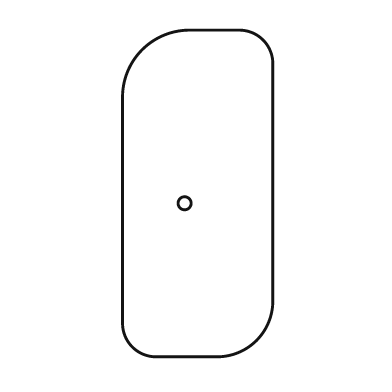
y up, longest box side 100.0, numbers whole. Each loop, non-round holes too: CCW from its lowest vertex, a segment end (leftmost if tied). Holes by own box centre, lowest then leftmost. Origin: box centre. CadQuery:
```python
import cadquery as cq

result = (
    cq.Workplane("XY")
    .moveTo(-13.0, -50.0)
    .lineTo(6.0, -50.0)
    .threePointArc((18.0, -45.0), (23.0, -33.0))
    .lineTo(23.0, 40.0)
    .threePointArc((20.0, 47.0), (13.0, 50.0))
    .lineTo(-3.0, 50.0)
    .threePointArc((-17.0, 44.0), (-23.0, 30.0))
    .lineTo(-23.0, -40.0)
    .threePointArc((-20.0, -47.0), (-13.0, -50.0))
    .close()
    .moveTo(-4.0, -3.0)
    .circle(2.0)
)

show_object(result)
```